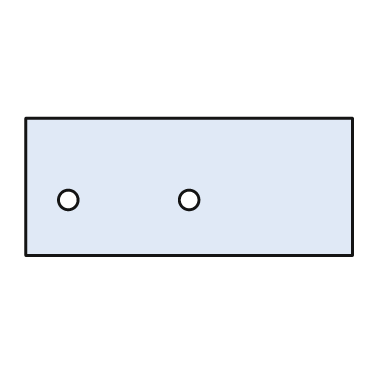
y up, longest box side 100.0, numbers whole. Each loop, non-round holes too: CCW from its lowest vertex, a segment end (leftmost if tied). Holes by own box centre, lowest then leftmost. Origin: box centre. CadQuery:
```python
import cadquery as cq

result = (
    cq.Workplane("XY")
    .moveTo(-50.0, -21.0)
    .lineTo(50.0, -21.0)
    .lineTo(50.0, 21.0)
    .lineTo(-50.0, 21.0)
    .close()
    .moveTo(-37.0, -4.0)
    .circle(3.0)
    .moveTo(0.0, -4.0)
    .circle(3.0)
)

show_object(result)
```